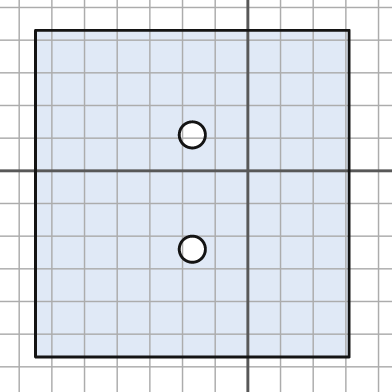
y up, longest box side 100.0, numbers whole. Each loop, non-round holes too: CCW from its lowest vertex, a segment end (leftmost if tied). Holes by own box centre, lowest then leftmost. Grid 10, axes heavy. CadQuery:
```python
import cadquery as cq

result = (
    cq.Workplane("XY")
    .moveTo(-65.0, -57.0)
    .lineTo(31.0, -57.0)
    .lineTo(31.0, 43.0)
    .lineTo(-65.0, 43.0)
    .close()
    .moveTo(-17.0, -24.0)
    .circle(4.0)
    .moveTo(-17.0, 11.0)
    .circle(4.0)
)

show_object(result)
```